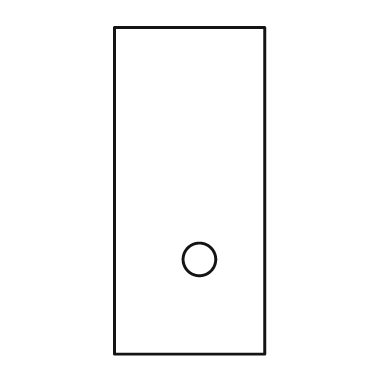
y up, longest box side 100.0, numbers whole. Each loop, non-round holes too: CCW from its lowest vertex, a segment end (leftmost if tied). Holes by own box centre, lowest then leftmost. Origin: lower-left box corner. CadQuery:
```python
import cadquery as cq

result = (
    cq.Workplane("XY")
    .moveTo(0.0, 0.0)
    .lineTo(46.0, 0.0)
    .lineTo(46.0, 100.0)
    .lineTo(0.0, 100.0)
    .close()
    .moveTo(26.0, 29.0)
    .circle(5.0)
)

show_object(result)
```